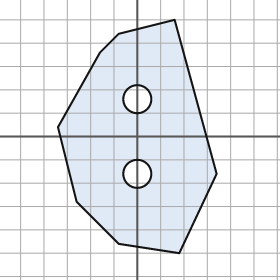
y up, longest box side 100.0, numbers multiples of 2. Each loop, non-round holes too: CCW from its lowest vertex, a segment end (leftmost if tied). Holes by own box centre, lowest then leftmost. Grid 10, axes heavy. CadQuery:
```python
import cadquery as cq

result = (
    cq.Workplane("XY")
    .moveTo(18.0, -50.0)
    .lineTo(34.0, -16.0)
    .lineTo(16.0, 50.0)
    .lineTo(-8.0, 44.0)
    .lineTo(-16.0, 36.0)
    .lineTo(-34.0, 4.0)
    .lineTo(-26.0, -28.0)
    .lineTo(-8.0, -46.0)
    .close()
    .moveTo(0.0, -16.0)
    .circle(6.0)
    .moveTo(0.0, 16.0)
    .circle(6.0)
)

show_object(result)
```